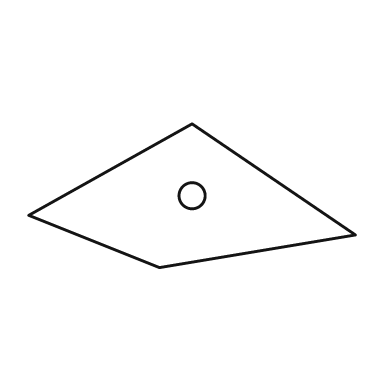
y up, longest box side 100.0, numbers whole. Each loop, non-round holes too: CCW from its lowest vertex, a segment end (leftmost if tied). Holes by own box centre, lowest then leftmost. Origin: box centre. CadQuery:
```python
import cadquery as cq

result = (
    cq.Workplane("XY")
    .moveTo(-10.0, -22.0)
    .lineTo(50.0, -12.0)
    .lineTo(0.0, 22.0)
    .lineTo(-50.0, -6.0)
    .close()
    .moveTo(0.0, 0.0)
    .circle(4.0)
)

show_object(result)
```